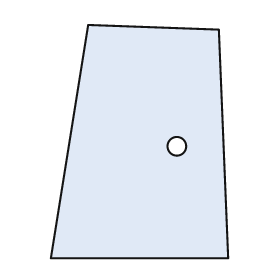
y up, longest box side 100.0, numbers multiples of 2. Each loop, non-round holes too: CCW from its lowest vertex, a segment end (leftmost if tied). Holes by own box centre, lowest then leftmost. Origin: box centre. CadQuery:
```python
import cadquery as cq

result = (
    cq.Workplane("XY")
    .moveTo(-38.0, -50.0)
    .lineTo(38.0, -50.0)
    .lineTo(34.0, 48.0)
    .lineTo(-22.0, 50.0)
    .close()
    .moveTo(16.0, -2.0)
    .circle(4.0)
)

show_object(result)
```